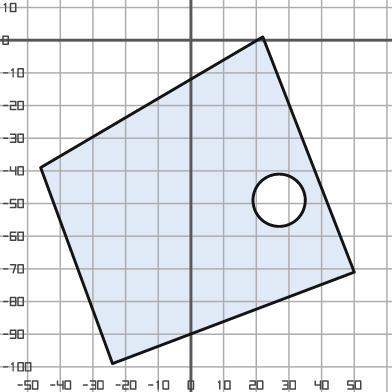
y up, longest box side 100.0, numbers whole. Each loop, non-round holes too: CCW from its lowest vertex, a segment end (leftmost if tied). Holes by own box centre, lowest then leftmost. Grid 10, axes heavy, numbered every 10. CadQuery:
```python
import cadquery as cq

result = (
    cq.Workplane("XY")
    .moveTo(-24.0, -99.0)
    .lineTo(50.0, -71.0)
    .lineTo(22.0, 1.0)
    .lineTo(-46.0, -39.0)
    .close()
    .moveTo(27.0, -49.0)
    .circle(8.0)
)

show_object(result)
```